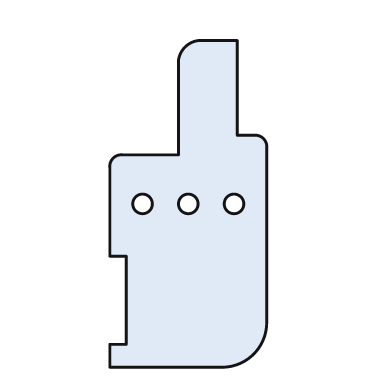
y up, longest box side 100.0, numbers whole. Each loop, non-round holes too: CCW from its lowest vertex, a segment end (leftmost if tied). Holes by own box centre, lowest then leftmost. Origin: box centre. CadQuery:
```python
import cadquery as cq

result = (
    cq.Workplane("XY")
    .moveTo(-24.0, -50.0)
    .lineTo(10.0, -50.0)
    .threePointArc((20.0, -46.0), (24.0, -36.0))
    .lineTo(24.0, 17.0)
    .threePointArc((23.0, 20.0), (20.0, 21.0))
    .lineTo(15.0, 21.0)
    .lineTo(15.0, 50.0)
    .lineTo(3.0, 50.0)
    .threePointArc((-1.0, 48.0), (-3.0, 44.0))
    .lineTo(-3.0, 15.0)
    .lineTo(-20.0, 15.0)
    .threePointArc((-23.0, 14.0), (-24.0, 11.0))
    .lineTo(-24.0, -16.0)
    .lineTo(-19.0, -16.0)
    .lineTo(-19.0, -43.0)
    .lineTo(-24.0, -43.0)
    .close()
    .moveTo(-14.0, 0.0)
    .circle(3.0)
    .moveTo(0.0, 0.0)
    .circle(3.0)
    .moveTo(14.0, 0.0)
    .circle(3.0)
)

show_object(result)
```